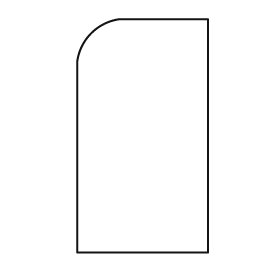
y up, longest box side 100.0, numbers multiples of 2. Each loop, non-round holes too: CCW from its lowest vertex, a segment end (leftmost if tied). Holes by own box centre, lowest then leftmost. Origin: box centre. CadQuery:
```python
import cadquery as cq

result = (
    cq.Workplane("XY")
    .moveTo(-28.0, -50.0)
    .lineTo(28.0, -50.0)
    .lineTo(28.0, 50.0)
    .lineTo(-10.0, 50.0)
    .threePointArc((-22.0, 44.0), (-28.0, 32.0))
    .close()
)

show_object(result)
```